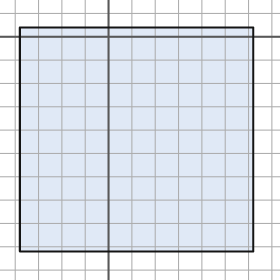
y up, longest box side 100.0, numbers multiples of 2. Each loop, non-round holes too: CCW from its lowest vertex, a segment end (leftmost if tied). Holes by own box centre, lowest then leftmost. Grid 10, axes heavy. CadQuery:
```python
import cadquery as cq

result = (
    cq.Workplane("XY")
    .moveTo(-38.0, -92.0)
    .lineTo(62.0, -92.0)
    .lineTo(62.0, 4.0)
    .lineTo(-38.0, 4.0)
    .close()
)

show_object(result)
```